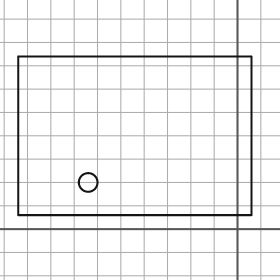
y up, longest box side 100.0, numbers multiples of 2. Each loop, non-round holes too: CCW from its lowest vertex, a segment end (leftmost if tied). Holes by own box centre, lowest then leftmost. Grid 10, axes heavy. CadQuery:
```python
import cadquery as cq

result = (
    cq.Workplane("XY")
    .moveTo(-94.0, 6.0)
    .lineTo(6.0, 6.0)
    .lineTo(6.0, 74.0)
    .lineTo(-94.0, 74.0)
    .close()
    .moveTo(-64.0, 20.0)
    .circle(4.0)
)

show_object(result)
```